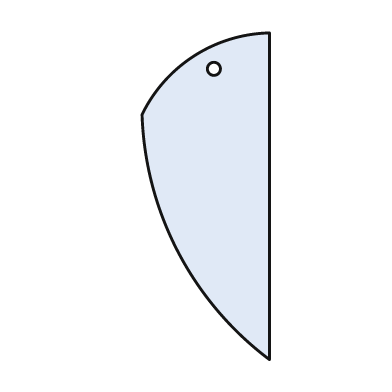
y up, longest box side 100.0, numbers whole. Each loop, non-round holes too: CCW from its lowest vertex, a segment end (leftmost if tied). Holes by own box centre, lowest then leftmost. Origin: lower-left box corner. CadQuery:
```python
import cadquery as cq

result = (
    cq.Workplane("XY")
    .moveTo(39.0, 0.0)
    .lineTo(39.0, 100.0)
    .threePointArc((16.0, 93.0), (0.0, 75.0))
    .threePointArc((11.0, 33.0), (39.0, 0.0))
    .close()
    .moveTo(22.0, 89.0)
    .circle(2.0)
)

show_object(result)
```